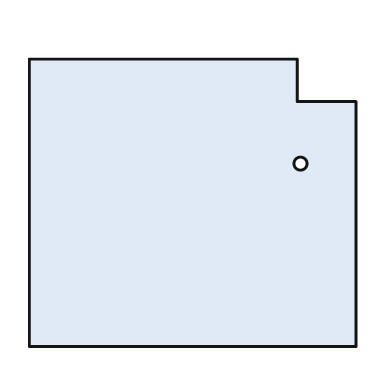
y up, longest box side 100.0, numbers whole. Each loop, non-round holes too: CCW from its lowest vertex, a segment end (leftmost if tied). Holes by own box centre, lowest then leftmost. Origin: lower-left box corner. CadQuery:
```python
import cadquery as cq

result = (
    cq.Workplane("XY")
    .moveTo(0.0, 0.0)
    .lineTo(100.0, 0.0)
    .lineTo(100.0, 75.0)
    .lineTo(82.0, 75.0)
    .lineTo(82.0, 88.0)
    .lineTo(0.0, 88.0)
    .close()
    .moveTo(83.0, 56.0)
    .circle(2.0)
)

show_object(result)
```